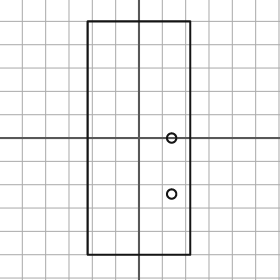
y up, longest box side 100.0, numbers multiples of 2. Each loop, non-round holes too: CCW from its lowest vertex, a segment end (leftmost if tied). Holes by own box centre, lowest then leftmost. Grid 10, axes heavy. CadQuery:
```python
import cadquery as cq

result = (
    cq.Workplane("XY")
    .moveTo(-22.0, -50.0)
    .lineTo(22.0, -50.0)
    .lineTo(22.0, 50.0)
    .lineTo(-22.0, 50.0)
    .close()
    .moveTo(14.0, -24.0)
    .circle(2.0)
    .moveTo(14.0, 0.0)
    .circle(2.0)
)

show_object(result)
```